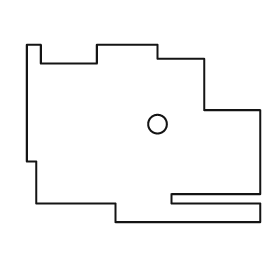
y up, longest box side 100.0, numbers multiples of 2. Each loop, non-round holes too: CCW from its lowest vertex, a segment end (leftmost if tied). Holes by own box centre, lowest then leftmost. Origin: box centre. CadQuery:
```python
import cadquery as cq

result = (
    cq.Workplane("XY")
    .moveTo(-12.0, -38.0)
    .lineTo(50.0, -38.0)
    .lineTo(50.0, -30.0)
    .lineTo(12.0, -30.0)
    .lineTo(12.0, -26.0)
    .lineTo(50.0, -26.0)
    .lineTo(50.0, 10.0)
    .lineTo(26.0, 10.0)
    .lineTo(26.0, 32.0)
    .lineTo(6.0, 32.0)
    .lineTo(6.0, 38.0)
    .lineTo(-20.0, 38.0)
    .lineTo(-20.0, 30.0)
    .lineTo(-44.0, 30.0)
    .lineTo(-44.0, 38.0)
    .lineTo(-50.0, 38.0)
    .lineTo(-50.0, -12.0)
    .lineTo(-46.0, -12.0)
    .lineTo(-46.0, -30.0)
    .lineTo(-12.0, -30.0)
    .close()
    .moveTo(6.0, 4.0)
    .circle(4.0)
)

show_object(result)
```